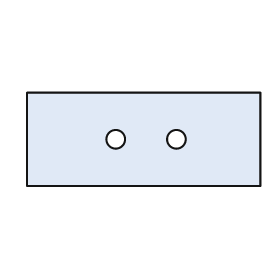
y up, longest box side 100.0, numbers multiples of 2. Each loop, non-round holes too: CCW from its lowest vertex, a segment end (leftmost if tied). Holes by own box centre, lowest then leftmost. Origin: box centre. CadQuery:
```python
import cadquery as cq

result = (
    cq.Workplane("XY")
    .moveTo(-50.0, -20.0)
    .lineTo(50.0, -20.0)
    .lineTo(50.0, 20.0)
    .lineTo(-50.0, 20.0)
    .close()
    .moveTo(-12.0, 0.0)
    .circle(4.0)
    .moveTo(14.0, 0.0)
    .circle(4.0)
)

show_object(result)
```